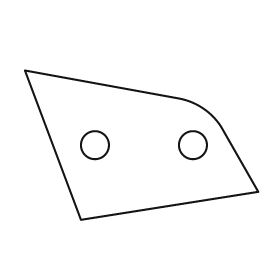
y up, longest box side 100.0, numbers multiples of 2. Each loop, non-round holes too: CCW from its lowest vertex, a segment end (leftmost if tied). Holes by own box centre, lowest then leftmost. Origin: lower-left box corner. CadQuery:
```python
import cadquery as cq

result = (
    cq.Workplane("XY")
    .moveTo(24.0, 0.0)
    .lineTo(100.0, 12.0)
    .lineTo(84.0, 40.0)
    .threePointArc((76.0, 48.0), (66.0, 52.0))
    .lineTo(0.0, 64.0)
    .close()
    .moveTo(30.0, 32.0)
    .circle(6.0)
    .moveTo(72.0, 32.0)
    .circle(6.0)
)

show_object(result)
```